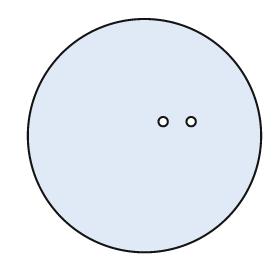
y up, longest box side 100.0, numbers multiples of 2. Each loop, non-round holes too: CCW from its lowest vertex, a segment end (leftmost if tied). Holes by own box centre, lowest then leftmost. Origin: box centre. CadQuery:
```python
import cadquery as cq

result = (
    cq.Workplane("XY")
    .moveTo(0.0, 0.0)
    .circle(50.0)
    .moveTo(8.0, 6.0)
    .circle(2.0)
    .moveTo(20.0, 6.0)
    .circle(2.0)
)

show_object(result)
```